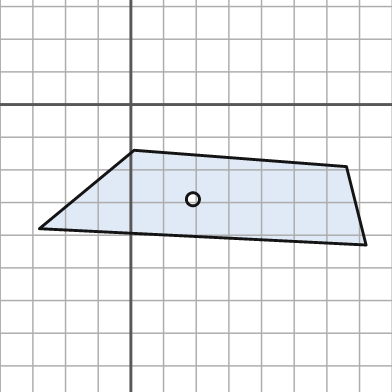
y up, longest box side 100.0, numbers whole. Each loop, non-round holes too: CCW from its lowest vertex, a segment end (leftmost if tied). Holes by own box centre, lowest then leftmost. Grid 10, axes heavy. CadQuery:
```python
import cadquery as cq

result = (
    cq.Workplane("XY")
    .moveTo(72.0, -43.0)
    .lineTo(66.0, -19.0)
    .lineTo(1.0, -14.0)
    .lineTo(-28.0, -38.0)
    .close()
    .moveTo(19.0, -29.0)
    .circle(2.0)
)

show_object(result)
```